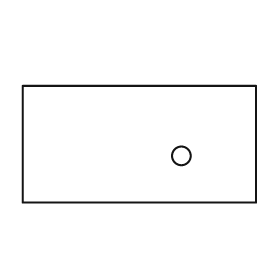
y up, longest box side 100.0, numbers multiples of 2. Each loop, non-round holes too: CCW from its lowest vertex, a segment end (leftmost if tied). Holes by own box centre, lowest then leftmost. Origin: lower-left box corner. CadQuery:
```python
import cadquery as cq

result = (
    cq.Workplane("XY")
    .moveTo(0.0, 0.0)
    .lineTo(100.0, 0.0)
    .lineTo(100.0, 50.0)
    .lineTo(0.0, 50.0)
    .close()
    .moveTo(68.0, 20.0)
    .circle(4.0)
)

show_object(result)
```